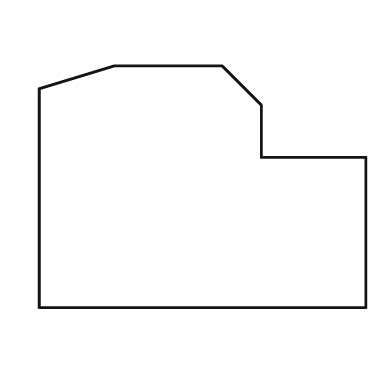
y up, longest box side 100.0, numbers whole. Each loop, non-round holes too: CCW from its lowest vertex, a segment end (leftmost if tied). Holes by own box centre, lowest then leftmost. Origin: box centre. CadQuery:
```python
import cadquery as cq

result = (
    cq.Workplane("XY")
    .moveTo(-50.0, -37.0)
    .lineTo(50.0, -37.0)
    .lineTo(50.0, 9.0)
    .lineTo(18.0, 9.0)
    .lineTo(18.0, 25.0)
    .lineTo(6.0, 37.0)
    .lineTo(-27.0, 37.0)
    .lineTo(-50.0, 30.0)
    .close()
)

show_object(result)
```